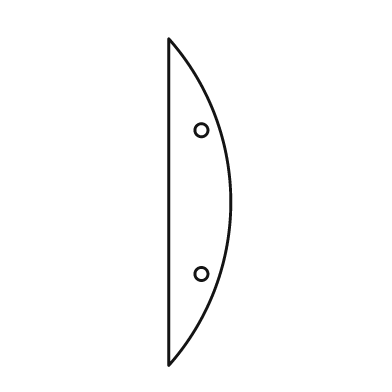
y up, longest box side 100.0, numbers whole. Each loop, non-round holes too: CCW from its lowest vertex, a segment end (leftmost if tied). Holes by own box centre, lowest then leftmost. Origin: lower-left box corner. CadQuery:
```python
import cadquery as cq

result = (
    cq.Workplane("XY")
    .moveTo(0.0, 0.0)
    .threePointArc((19.0, 50.0), (0.0, 100.0))
    .close()
    .moveTo(10.0, 28.0)
    .circle(2.0)
    .moveTo(10.0, 72.0)
    .circle(2.0)
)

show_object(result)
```